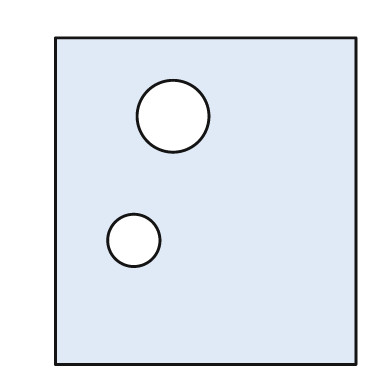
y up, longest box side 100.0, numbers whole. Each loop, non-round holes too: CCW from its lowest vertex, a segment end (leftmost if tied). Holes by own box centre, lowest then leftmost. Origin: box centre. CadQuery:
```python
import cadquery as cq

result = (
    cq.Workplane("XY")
    .moveTo(-46.0, -50.0)
    .lineTo(46.0, -50.0)
    .lineTo(46.0, 50.0)
    .lineTo(-46.0, 50.0)
    .close()
    .moveTo(-22.0, -12.0)
    .circle(8.0)
    .moveTo(-10.0, 26.0)
    .circle(11.0)
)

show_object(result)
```